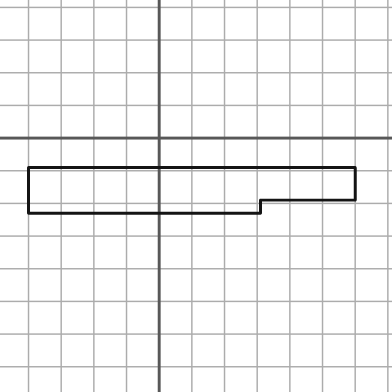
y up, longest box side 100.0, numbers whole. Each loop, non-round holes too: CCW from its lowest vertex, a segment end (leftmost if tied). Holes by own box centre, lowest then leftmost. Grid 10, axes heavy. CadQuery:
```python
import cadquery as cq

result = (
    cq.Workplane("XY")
    .moveTo(-40.0, -23.0)
    .lineTo(31.0, -23.0)
    .lineTo(31.0, -19.0)
    .lineTo(60.0, -19.0)
    .lineTo(60.0, -9.0)
    .lineTo(-40.0, -9.0)
    .close()
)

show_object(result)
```